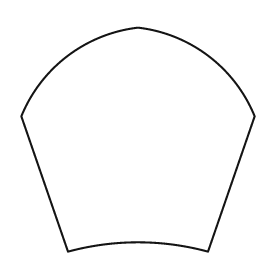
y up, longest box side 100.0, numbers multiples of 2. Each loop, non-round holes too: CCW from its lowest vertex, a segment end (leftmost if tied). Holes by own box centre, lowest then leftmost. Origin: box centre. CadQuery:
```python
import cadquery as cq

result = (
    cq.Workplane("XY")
    .moveTo(-30.0, -48.0)
    .threePointArc((0.0, -44.0), (30.0, -48.0))
    .lineTo(50.0, 10.0)
    .threePointArc((30.0, 36.0), (0.0, 48.0))
    .threePointArc((-30.0, 36.0), (-50.0, 10.0))
    .close()
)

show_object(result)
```